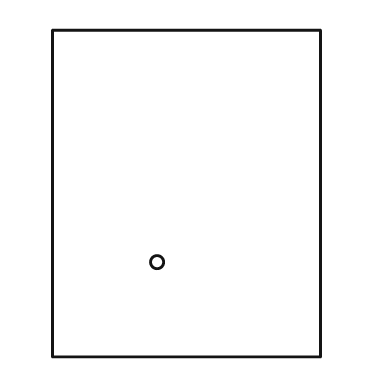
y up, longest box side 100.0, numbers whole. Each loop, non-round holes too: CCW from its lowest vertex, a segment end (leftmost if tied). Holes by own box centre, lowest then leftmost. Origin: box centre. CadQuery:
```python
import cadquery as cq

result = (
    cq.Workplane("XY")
    .moveTo(-41.0, -50.0)
    .lineTo(41.0, -50.0)
    .lineTo(41.0, 50.0)
    .lineTo(-41.0, 50.0)
    .close()
    .moveTo(-9.0, -21.0)
    .circle(2.0)
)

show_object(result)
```